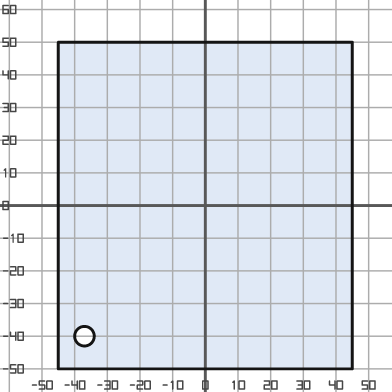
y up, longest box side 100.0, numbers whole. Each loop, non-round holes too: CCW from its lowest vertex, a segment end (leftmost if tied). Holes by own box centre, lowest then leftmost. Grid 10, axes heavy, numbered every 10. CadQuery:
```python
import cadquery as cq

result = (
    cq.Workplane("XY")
    .moveTo(-45.0, -50.0)
    .lineTo(45.0, -50.0)
    .lineTo(45.0, 50.0)
    .lineTo(-45.0, 50.0)
    .close()
    .moveTo(-37.0, -40.0)
    .circle(3.0)
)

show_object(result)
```